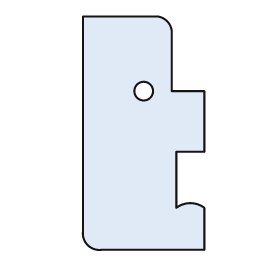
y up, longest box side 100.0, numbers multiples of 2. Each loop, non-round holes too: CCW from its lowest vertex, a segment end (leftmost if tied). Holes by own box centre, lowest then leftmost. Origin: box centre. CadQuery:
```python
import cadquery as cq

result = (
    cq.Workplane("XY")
    .moveTo(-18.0, -50.0)
    .lineTo(26.0, -50.0)
    .lineTo(26.0, -32.0)
    .threePointArc((20.0, -30.0), (14.0, -32.0))
    .lineTo(14.0, -8.0)
    .lineTo(26.0, -8.0)
    .lineTo(26.0, 18.0)
    .lineTo(12.0, 18.0)
    .lineTo(12.0, 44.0)
    .threePointArc((10.0, 48.0), (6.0, 50.0))
    .lineTo(-26.0, 50.0)
    .lineTo(-26.0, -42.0)
    .threePointArc((-24.0, -48.0), (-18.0, -50.0))
    .close()
    .moveTo(0.0, 18.0)
    .circle(4.0)
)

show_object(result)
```